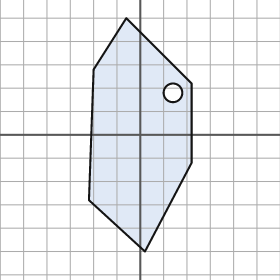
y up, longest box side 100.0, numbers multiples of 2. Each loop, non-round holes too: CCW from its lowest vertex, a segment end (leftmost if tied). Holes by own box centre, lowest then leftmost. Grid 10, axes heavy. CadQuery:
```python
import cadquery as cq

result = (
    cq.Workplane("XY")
    .moveTo(2.0, -50.0)
    .lineTo(22.0, -12.0)
    .lineTo(22.0, 22.0)
    .lineTo(-6.0, 50.0)
    .lineTo(-20.0, 28.0)
    .lineTo(-22.0, -28.0)
    .close()
    .moveTo(14.0, 18.0)
    .circle(4.0)
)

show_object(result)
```